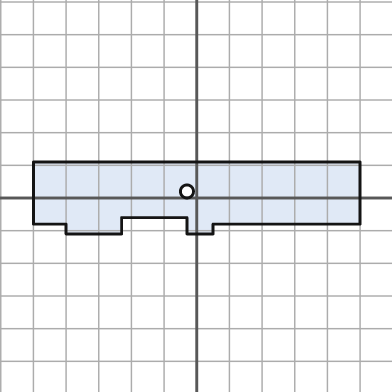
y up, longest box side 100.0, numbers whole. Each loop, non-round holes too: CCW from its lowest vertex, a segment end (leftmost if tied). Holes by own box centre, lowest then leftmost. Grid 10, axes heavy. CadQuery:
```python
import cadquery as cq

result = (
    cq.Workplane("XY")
    .moveTo(-40.0, -11.0)
    .lineTo(-23.0, -11.0)
    .lineTo(-23.0, -6.0)
    .lineTo(-3.0, -6.0)
    .lineTo(-3.0, -11.0)
    .lineTo(5.0, -11.0)
    .lineTo(5.0, -8.0)
    .lineTo(50.0, -8.0)
    .lineTo(50.0, 11.0)
    .lineTo(-50.0, 11.0)
    .lineTo(-50.0, -8.0)
    .lineTo(-40.0, -8.0)
    .close()
    .moveTo(-3.0, 2.0)
    .circle(2.0)
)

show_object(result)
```